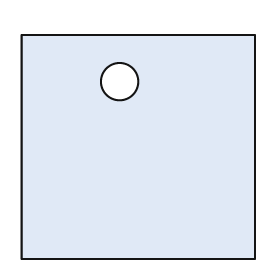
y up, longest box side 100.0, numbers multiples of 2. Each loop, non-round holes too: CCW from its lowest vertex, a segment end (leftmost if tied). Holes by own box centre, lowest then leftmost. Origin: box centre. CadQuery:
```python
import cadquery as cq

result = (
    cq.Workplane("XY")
    .moveTo(-50.0, -48.0)
    .lineTo(50.0, -48.0)
    .lineTo(50.0, 48.0)
    .lineTo(-50.0, 48.0)
    .close()
    .moveTo(-8.0, 28.0)
    .circle(8.0)
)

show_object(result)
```